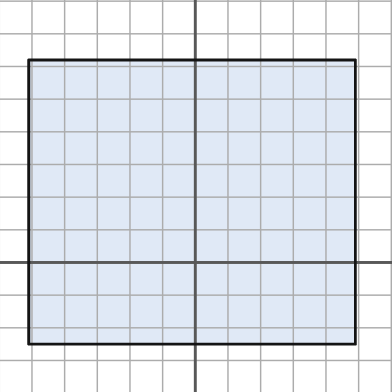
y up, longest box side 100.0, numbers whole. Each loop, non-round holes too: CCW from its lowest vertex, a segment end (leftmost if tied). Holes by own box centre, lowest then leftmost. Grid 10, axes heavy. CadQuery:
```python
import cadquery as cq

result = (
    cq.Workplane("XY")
    .moveTo(-51.0, -25.0)
    .lineTo(49.0, -25.0)
    .lineTo(49.0, 62.0)
    .lineTo(-51.0, 62.0)
    .close()
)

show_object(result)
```